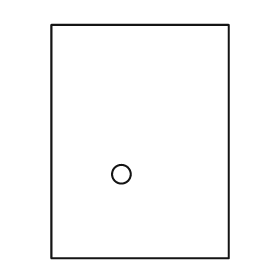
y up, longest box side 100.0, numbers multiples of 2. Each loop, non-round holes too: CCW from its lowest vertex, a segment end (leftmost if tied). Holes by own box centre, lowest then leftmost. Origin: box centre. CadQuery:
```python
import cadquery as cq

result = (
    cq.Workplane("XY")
    .moveTo(-38.0, -50.0)
    .lineTo(38.0, -50.0)
    .lineTo(38.0, 50.0)
    .lineTo(-38.0, 50.0)
    .close()
    .moveTo(-8.0, -14.0)
    .circle(4.0)
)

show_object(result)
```